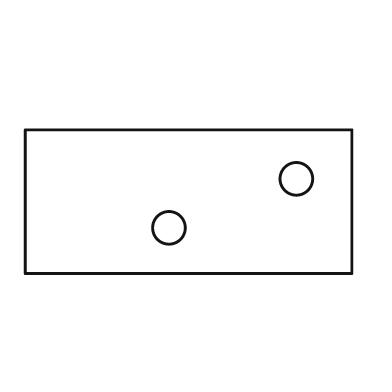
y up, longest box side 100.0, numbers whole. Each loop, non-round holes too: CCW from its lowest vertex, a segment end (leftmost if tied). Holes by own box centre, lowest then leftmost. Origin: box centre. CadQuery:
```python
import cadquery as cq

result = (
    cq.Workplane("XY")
    .moveTo(-50.0, -22.0)
    .lineTo(50.0, -22.0)
    .lineTo(50.0, 22.0)
    .lineTo(-50.0, 22.0)
    .close()
    .moveTo(-6.0, -8.0)
    .circle(5.0)
    .moveTo(33.0, 7.0)
    .circle(5.0)
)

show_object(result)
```